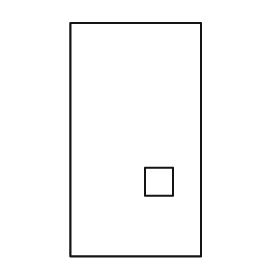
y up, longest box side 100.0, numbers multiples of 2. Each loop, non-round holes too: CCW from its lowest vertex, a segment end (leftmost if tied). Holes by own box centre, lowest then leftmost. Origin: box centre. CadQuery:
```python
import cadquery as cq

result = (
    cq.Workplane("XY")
    .moveTo(-28.0, -50.0)
    .lineTo(28.0, -50.0)
    .lineTo(28.0, 50.0)
    .lineTo(-28.0, 50.0)
    .close()
    .moveTo(4.0, -24.0)
    .lineTo(16.0, -24.0)
    .lineTo(16.0, -12.0)
    .lineTo(4.0, -12.0)
    .close()
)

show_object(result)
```